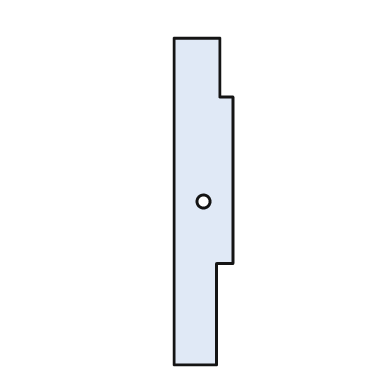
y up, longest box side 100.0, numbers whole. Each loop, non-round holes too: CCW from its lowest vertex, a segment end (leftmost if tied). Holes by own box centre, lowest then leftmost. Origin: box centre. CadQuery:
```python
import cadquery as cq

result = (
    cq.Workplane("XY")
    .moveTo(-9.0, -50.0)
    .lineTo(4.0, -50.0)
    .lineTo(4.0, -19.0)
    .lineTo(9.0, -19.0)
    .lineTo(9.0, 32.0)
    .lineTo(5.0, 32.0)
    .lineTo(5.0, 50.0)
    .lineTo(-9.0, 50.0)
    .close()
    .moveTo(0.0, 0.0)
    .circle(2.0)
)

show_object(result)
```